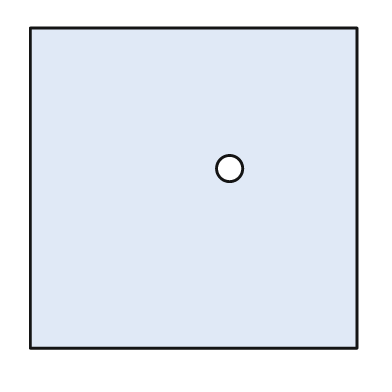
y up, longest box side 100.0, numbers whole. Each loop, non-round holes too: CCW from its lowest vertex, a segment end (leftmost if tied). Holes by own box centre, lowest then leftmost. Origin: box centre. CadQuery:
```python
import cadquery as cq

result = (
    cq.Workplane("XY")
    .moveTo(-50.0, -49.0)
    .lineTo(50.0, -49.0)
    .lineTo(50.0, 49.0)
    .lineTo(-50.0, 49.0)
    .close()
    .moveTo(11.0, 6.0)
    .circle(4.0)
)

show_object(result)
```